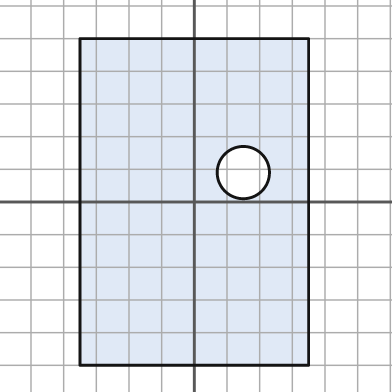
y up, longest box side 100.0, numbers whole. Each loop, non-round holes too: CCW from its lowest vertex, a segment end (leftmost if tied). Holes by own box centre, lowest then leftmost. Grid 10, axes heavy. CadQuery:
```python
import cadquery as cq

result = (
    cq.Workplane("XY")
    .moveTo(-35.0, -50.0)
    .lineTo(35.0, -50.0)
    .lineTo(35.0, 50.0)
    .lineTo(-35.0, 50.0)
    .close()
    .moveTo(15.0, 9.0)
    .circle(8.0)
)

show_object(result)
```